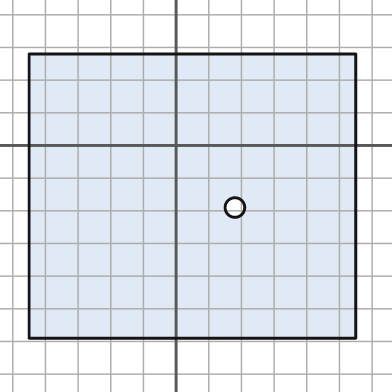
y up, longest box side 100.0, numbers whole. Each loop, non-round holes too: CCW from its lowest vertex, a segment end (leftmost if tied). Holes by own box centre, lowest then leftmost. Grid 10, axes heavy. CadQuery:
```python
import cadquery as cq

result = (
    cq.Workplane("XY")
    .moveTo(-45.0, -59.0)
    .lineTo(55.0, -59.0)
    .lineTo(55.0, 28.0)
    .lineTo(-45.0, 28.0)
    .close()
    .moveTo(18.0, -19.0)
    .circle(3.0)
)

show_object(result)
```